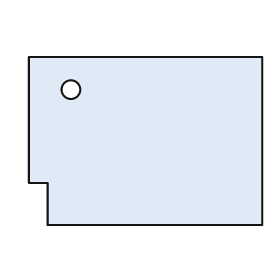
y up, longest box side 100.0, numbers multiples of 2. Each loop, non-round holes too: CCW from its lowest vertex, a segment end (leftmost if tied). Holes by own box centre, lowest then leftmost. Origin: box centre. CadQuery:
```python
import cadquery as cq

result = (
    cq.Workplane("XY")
    .moveTo(-42.0, -36.0)
    .lineTo(50.0, -36.0)
    .lineTo(50.0, 36.0)
    .lineTo(-50.0, 36.0)
    .lineTo(-50.0, -18.0)
    .lineTo(-42.0, -18.0)
    .close()
    .moveTo(-32.0, 22.0)
    .circle(4.0)
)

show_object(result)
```